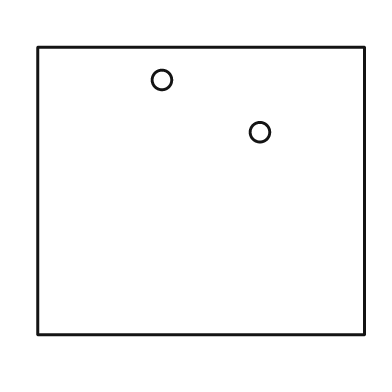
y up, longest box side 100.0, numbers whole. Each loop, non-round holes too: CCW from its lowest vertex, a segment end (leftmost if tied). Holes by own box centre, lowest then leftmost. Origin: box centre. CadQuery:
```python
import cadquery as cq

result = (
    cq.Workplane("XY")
    .moveTo(-50.0, -44.0)
    .lineTo(50.0, -44.0)
    .lineTo(50.0, 44.0)
    .lineTo(-50.0, 44.0)
    .close()
    .moveTo(18.0, 18.0)
    .circle(3.0)
    .moveTo(-12.0, 34.0)
    .circle(3.0)
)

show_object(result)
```